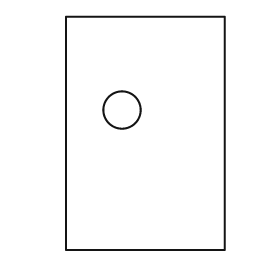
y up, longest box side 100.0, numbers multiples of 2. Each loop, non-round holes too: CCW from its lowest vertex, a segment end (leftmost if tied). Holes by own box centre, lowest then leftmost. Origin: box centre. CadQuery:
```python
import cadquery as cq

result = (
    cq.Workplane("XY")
    .moveTo(-34.0, -50.0)
    .lineTo(34.0, -50.0)
    .lineTo(34.0, 50.0)
    .lineTo(-34.0, 50.0)
    .close()
    .moveTo(-10.0, 10.0)
    .circle(8.0)
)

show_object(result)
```